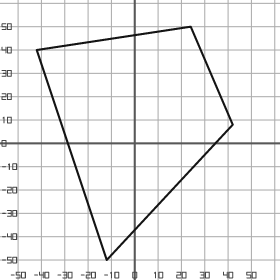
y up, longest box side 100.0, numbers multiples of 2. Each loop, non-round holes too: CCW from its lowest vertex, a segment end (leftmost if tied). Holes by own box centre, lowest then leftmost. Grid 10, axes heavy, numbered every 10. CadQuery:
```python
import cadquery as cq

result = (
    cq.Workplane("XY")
    .moveTo(-12.0, -50.0)
    .lineTo(42.0, 8.0)
    .lineTo(24.0, 50.0)
    .lineTo(-42.0, 40.0)
    .close()
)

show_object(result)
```